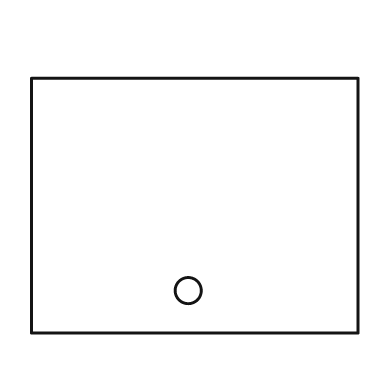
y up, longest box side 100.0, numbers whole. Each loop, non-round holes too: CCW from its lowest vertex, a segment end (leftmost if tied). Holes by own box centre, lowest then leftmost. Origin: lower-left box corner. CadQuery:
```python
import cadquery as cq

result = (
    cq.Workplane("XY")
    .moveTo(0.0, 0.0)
    .lineTo(100.0, 0.0)
    .lineTo(100.0, 78.0)
    .lineTo(0.0, 78.0)
    .close()
    .moveTo(48.0, 13.0)
    .circle(4.0)
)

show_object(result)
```